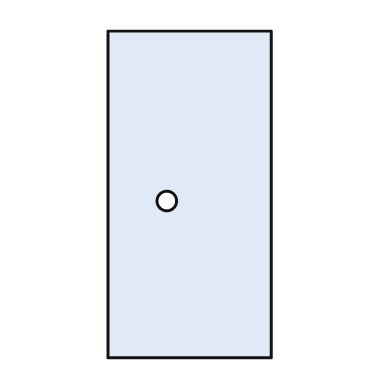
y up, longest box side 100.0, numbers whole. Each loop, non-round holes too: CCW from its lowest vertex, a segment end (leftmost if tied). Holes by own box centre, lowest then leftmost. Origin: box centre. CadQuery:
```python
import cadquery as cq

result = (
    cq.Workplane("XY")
    .moveTo(-25.0, -50.0)
    .lineTo(25.0, -50.0)
    .lineTo(25.0, 50.0)
    .lineTo(-25.0, 50.0)
    .close()
    .moveTo(-7.0, -2.0)
    .circle(3.0)
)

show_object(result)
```